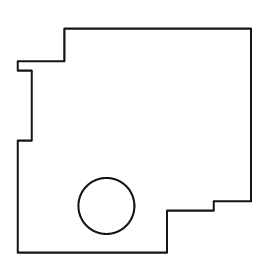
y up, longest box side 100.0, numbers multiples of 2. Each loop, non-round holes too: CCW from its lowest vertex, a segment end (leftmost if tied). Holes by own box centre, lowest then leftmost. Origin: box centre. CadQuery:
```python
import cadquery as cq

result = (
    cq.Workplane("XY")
    .moveTo(-50.0, -48.0)
    .lineTo(14.0, -48.0)
    .lineTo(14.0, -30.0)
    .lineTo(34.0, -30.0)
    .lineTo(34.0, -26.0)
    .lineTo(50.0, -26.0)
    .lineTo(50.0, 48.0)
    .lineTo(-30.0, 48.0)
    .lineTo(-30.0, 34.0)
    .lineTo(-50.0, 34.0)
    .lineTo(-50.0, 30.0)
    .lineTo(-44.0, 30.0)
    .lineTo(-44.0, 0.0)
    .lineTo(-50.0, 0.0)
    .close()
    .moveTo(-12.0, -28.0)
    .circle(12.0)
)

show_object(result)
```